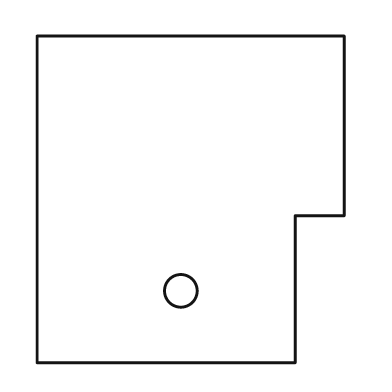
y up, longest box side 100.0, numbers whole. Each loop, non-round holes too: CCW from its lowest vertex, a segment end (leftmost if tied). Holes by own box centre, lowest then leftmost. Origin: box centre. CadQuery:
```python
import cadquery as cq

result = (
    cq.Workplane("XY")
    .moveTo(-47.0, -50.0)
    .lineTo(32.0, -50.0)
    .lineTo(32.0, -5.0)
    .lineTo(47.0, -5.0)
    .lineTo(47.0, 50.0)
    .lineTo(-47.0, 50.0)
    .close()
    .moveTo(-3.0, -28.0)
    .circle(5.0)
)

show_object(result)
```